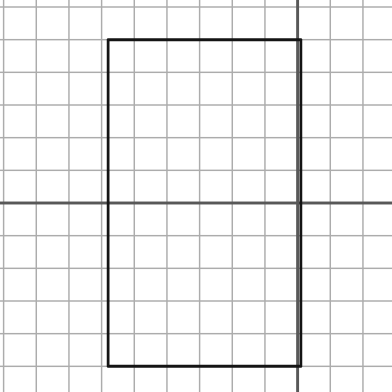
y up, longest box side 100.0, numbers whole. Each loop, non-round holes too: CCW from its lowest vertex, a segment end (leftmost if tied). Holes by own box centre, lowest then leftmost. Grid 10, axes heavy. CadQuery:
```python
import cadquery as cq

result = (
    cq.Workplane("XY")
    .moveTo(-58.0, -50.0)
    .lineTo(1.0, -50.0)
    .lineTo(1.0, 50.0)
    .lineTo(-58.0, 50.0)
    .close()
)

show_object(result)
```